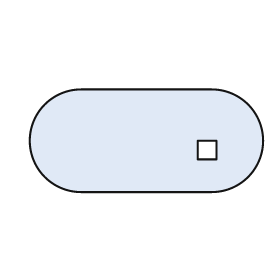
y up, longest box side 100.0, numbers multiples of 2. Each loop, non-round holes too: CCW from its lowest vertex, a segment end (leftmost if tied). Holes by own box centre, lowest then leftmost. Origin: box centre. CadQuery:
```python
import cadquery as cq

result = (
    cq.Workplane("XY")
    .moveTo(-28.0, -22.0)
    .lineTo(28.0, -22.0)
    .threePointArc((50.0, 0.0), (28.0, 22.0))
    .lineTo(-28.0, 22.0)
    .threePointArc((-50.0, 0.0), (-28.0, -22.0))
    .close()
    .moveTo(22.0, -8.0)
    .lineTo(30.0, -8.0)
    .lineTo(30.0, 0.0)
    .lineTo(22.0, 0.0)
    .close()
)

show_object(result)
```